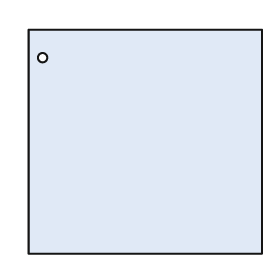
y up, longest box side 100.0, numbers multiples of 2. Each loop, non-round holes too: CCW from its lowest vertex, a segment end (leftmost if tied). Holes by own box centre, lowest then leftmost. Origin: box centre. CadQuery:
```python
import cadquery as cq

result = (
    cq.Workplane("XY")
    .moveTo(-50.0, -48.0)
    .lineTo(50.0, -48.0)
    .lineTo(50.0, 48.0)
    .lineTo(-50.0, 48.0)
    .close()
    .moveTo(-44.0, 36.0)
    .circle(2.0)
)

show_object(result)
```